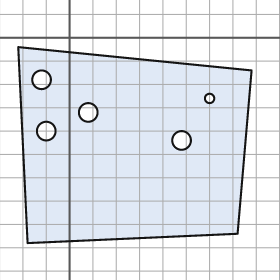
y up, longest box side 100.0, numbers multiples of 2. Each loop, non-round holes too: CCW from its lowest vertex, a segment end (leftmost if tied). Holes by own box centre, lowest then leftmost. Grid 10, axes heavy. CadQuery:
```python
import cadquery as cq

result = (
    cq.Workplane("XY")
    .moveTo(-18.0, -88.0)
    .lineTo(72.0, -84.0)
    .lineTo(78.0, -14.0)
    .lineTo(-22.0, -4.0)
    .close()
    .moveTo(48.0, -44.0)
    .circle(4.0)
    .moveTo(-10.0, -40.0)
    .circle(4.0)
    .moveTo(8.0, -32.0)
    .circle(4.0)
    .moveTo(60.0, -26.0)
    .circle(2.0)
    .moveTo(-12.0, -18.0)
    .circle(4.0)
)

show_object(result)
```